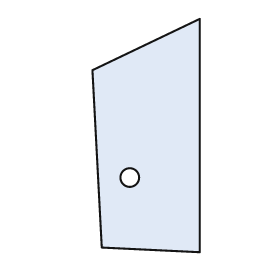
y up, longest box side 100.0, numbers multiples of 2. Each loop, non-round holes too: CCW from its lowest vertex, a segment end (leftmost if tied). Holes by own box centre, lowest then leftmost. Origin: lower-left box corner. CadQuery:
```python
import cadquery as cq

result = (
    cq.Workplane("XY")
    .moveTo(46.0, 0.0)
    .lineTo(46.0, 100.0)
    .lineTo(0.0, 78.0)
    .lineTo(4.0, 2.0)
    .close()
    .moveTo(16.0, 32.0)
    .circle(4.0)
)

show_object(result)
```